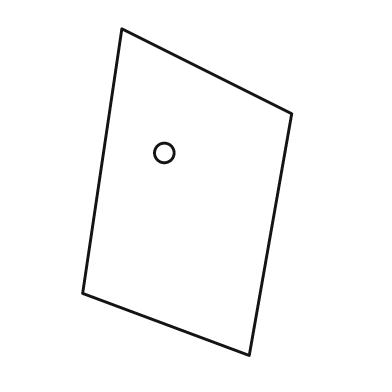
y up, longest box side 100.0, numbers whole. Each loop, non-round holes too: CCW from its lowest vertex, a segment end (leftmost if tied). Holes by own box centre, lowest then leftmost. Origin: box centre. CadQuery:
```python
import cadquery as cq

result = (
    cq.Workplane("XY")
    .moveTo(19.0, -50.0)
    .lineTo(32.0, 24.0)
    .lineTo(-20.0, 50.0)
    .lineTo(-32.0, -31.0)
    .close()
    .moveTo(-7.0, 12.0)
    .circle(3.0)
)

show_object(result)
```